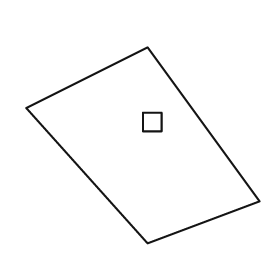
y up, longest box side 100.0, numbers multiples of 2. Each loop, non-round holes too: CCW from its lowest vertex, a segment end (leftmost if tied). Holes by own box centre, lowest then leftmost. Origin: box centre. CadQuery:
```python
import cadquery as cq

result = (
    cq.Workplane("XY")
    .moveTo(2.0, -42.0)
    .lineTo(50.0, -24.0)
    .lineTo(2.0, 42.0)
    .lineTo(-50.0, 16.0)
    .close()
    .moveTo(0.0, 6.0)
    .lineTo(8.0, 6.0)
    .lineTo(8.0, 14.0)
    .lineTo(0.0, 14.0)
    .close()
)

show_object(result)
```